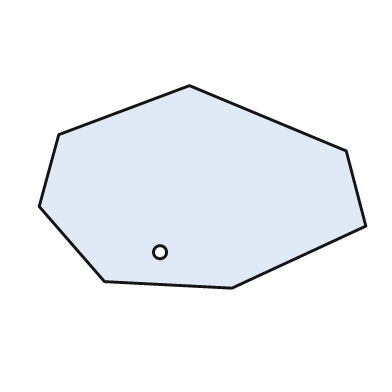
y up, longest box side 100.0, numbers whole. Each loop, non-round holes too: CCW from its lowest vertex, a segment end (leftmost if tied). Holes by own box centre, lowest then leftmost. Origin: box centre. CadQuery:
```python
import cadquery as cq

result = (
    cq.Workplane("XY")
    .moveTo(9.0, -31.0)
    .lineTo(50.0, -12.0)
    .lineTo(44.0, 11.0)
    .lineTo(-4.0, 31.0)
    .lineTo(-44.0, 16.0)
    .lineTo(-50.0, -6.0)
    .lineTo(-30.0, -29.0)
    .close()
    .moveTo(-13.0, -20.0)
    .circle(2.0)
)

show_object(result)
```